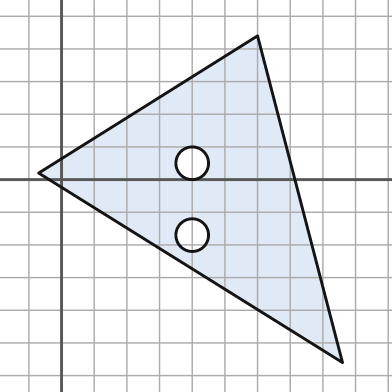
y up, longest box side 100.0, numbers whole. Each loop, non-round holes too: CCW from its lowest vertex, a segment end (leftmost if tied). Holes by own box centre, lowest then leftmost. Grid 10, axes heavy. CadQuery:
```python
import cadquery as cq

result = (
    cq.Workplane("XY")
    .moveTo(86.0, -56.0)
    .lineTo(60.0, 44.0)
    .lineTo(-7.0, 2.0)
    .close()
    .moveTo(40.0, -17.0)
    .circle(5.0)
    .moveTo(40.0, 5.0)
    .circle(5.0)
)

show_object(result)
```